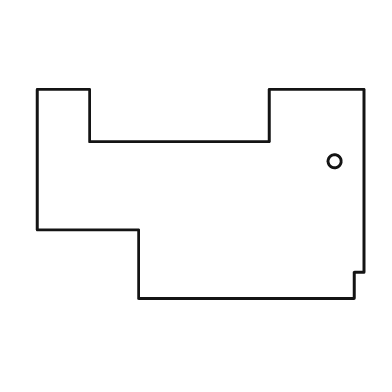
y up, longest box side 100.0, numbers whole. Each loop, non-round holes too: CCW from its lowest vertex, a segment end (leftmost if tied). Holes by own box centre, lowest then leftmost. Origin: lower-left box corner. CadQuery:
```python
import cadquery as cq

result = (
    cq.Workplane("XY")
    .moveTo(31.0, 0.0)
    .lineTo(97.0, 0.0)
    .lineTo(97.0, 8.0)
    .lineTo(100.0, 8.0)
    .lineTo(100.0, 64.0)
    .lineTo(71.0, 64.0)
    .lineTo(71.0, 48.0)
    .lineTo(16.0, 48.0)
    .lineTo(16.0, 64.0)
    .lineTo(0.0, 64.0)
    .lineTo(0.0, 21.0)
    .lineTo(31.0, 21.0)
    .close()
    .moveTo(91.0, 42.0)
    .circle(2.0)
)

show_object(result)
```